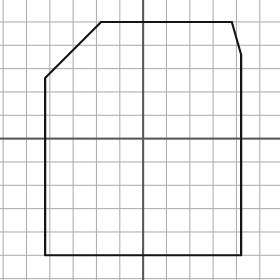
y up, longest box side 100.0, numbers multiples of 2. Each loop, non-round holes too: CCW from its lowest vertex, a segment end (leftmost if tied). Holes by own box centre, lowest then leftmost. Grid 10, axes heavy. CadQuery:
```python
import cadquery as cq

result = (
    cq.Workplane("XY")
    .moveTo(-42.0, -50.0)
    .lineTo(42.0, -50.0)
    .lineTo(42.0, 36.0)
    .lineTo(38.0, 50.0)
    .lineTo(-18.0, 50.0)
    .lineTo(-42.0, 26.0)
    .close()
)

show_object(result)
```